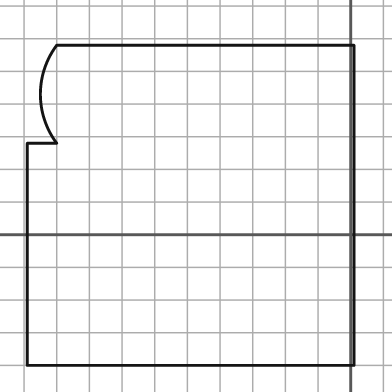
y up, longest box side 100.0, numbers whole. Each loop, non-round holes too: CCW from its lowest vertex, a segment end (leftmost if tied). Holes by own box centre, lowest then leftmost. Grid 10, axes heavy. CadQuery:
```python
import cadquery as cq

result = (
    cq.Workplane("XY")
    .moveTo(-99.0, -40.0)
    .lineTo(1.0, -40.0)
    .lineTo(1.0, 58.0)
    .lineTo(-90.0, 58.0)
    .threePointArc((-95.0, 43.0), (-90.0, 28.0))
    .lineTo(-99.0, 28.0)
    .close()
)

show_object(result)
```